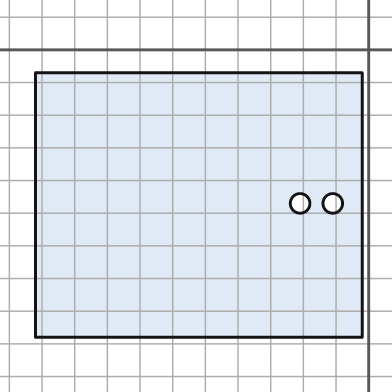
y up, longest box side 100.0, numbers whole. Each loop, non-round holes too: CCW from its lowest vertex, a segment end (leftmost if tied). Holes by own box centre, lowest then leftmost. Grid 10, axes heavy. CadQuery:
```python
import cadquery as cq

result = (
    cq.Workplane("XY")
    .moveTo(-102.0, -88.0)
    .lineTo(-2.0, -88.0)
    .lineTo(-2.0, -7.0)
    .lineTo(-102.0, -7.0)
    .close()
    .moveTo(-21.0, -47.0)
    .circle(3.0)
    .moveTo(-11.0, -47.0)
    .circle(3.0)
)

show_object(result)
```